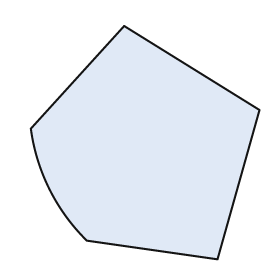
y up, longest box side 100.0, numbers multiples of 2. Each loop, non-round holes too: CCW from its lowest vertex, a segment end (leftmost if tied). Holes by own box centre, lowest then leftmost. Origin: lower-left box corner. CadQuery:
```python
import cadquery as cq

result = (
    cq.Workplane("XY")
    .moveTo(80.0, 0.0)
    .lineTo(98.0, 64.0)
    .lineTo(40.0, 100.0)
    .lineTo(0.0, 56.0)
    .threePointArc((8.0, 30.0), (24.0, 8.0))
    .close()
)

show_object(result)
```